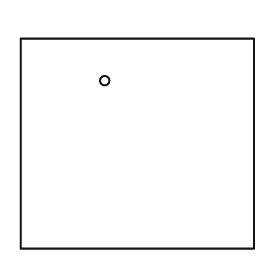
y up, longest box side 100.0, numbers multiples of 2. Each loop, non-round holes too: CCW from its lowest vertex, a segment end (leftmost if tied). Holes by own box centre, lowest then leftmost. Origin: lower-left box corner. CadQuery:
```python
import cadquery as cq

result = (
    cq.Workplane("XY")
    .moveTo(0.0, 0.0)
    .lineTo(100.0, 0.0)
    .lineTo(100.0, 90.0)
    .lineTo(0.0, 90.0)
    .close()
    .moveTo(36.0, 72.0)
    .circle(2.0)
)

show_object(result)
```